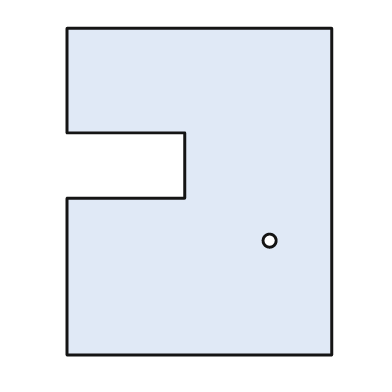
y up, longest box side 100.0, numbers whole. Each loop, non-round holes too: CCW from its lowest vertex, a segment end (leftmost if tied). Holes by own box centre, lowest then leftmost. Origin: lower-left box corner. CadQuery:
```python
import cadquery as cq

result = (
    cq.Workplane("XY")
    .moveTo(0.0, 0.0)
    .lineTo(81.0, 0.0)
    .lineTo(81.0, 100.0)
    .lineTo(0.0, 100.0)
    .lineTo(0.0, 68.0)
    .lineTo(36.0, 68.0)
    .lineTo(36.0, 48.0)
    .lineTo(0.0, 48.0)
    .close()
    .moveTo(62.0, 35.0)
    .circle(2.0)
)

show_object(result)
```